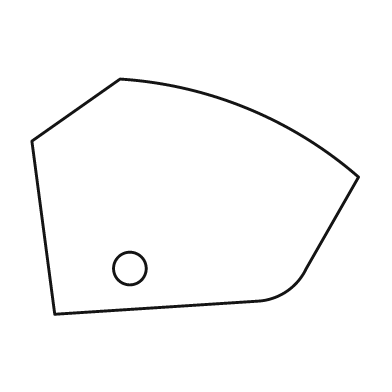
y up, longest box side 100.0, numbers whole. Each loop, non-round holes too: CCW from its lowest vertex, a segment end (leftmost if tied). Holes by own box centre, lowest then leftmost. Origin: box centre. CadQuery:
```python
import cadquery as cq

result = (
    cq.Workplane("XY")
    .moveTo(-43.0, -36.0)
    .lineTo(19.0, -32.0)
    .threePointArc((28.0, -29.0), (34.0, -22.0))
    .lineTo(50.0, 6.0)
    .threePointArc((16.0, 27.0), (-23.0, 36.0))
    .lineTo(-50.0, 17.0)
    .close()
    .moveTo(-20.0, -22.0)
    .circle(5.0)
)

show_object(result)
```